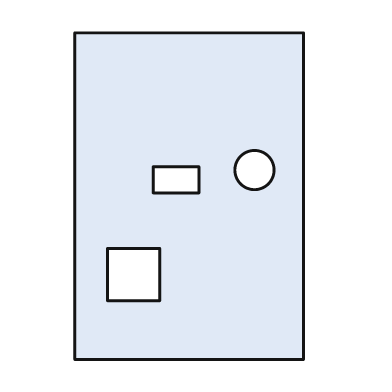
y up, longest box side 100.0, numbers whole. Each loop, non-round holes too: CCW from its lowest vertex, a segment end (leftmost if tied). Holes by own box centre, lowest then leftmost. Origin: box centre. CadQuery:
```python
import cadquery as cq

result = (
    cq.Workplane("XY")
    .moveTo(-35.0, -50.0)
    .lineTo(35.0, -50.0)
    .lineTo(35.0, 50.0)
    .lineTo(-35.0, 50.0)
    .close()
    .moveTo(-25.0, -32.0)
    .lineTo(-9.0, -32.0)
    .lineTo(-9.0, -16.0)
    .lineTo(-25.0, -16.0)
    .close()
    .moveTo(-11.0, 1.0)
    .lineTo(3.0, 1.0)
    .lineTo(3.0, 9.0)
    .lineTo(-11.0, 9.0)
    .close()
    .moveTo(20.0, 8.0)
    .circle(6.0)
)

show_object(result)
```